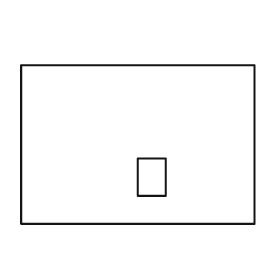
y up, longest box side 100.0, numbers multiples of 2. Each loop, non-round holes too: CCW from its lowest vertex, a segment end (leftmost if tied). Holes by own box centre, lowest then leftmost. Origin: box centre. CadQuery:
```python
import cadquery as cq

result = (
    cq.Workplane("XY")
    .moveTo(-50.0, -34.0)
    .lineTo(50.0, -34.0)
    .lineTo(50.0, 34.0)
    .lineTo(-50.0, 34.0)
    .close()
    .moveTo(0.0, -22.0)
    .lineTo(12.0, -22.0)
    .lineTo(12.0, -6.0)
    .lineTo(0.0, -6.0)
    .close()
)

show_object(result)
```